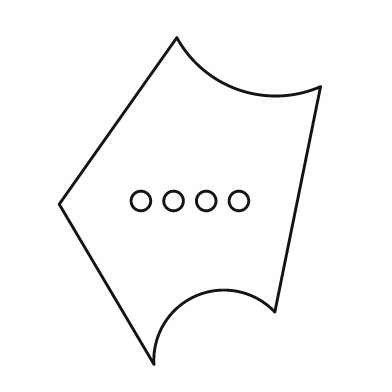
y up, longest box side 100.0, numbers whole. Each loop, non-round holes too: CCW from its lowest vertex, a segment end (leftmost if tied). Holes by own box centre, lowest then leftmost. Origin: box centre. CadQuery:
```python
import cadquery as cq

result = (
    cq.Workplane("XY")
    .moveTo(-11.0, -50.0)
    .threePointArc((2.0, -29.0), (26.0, -34.0))
    .lineTo(40.0, 35.0)
    .threePointArc((15.0, 34.0), (-4.0, 50.0))
    .lineTo(-40.0, -1.0)
    .close()
    .moveTo(-15.0, 0.0)
    .circle(3.0)
    .moveTo(-5.0, 0.0)
    .circle(3.0)
    .moveTo(5.0, 0.0)
    .circle(3.0)
    .moveTo(15.0, 0.0)
    .circle(3.0)
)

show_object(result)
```